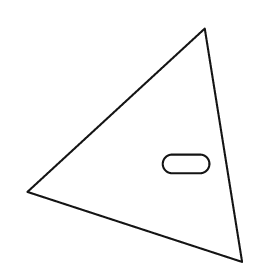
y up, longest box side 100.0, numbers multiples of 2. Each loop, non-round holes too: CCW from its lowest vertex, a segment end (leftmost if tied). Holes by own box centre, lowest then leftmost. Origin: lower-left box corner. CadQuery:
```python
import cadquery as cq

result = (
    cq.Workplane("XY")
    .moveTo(92.0, 0.0)
    .lineTo(76.0, 100.0)
    .lineTo(0.0, 30.0)
    .close()
    .moveTo(62.0, 38.0)
    .lineTo(74.0, 38.0)
    .threePointArc((78.0, 42.0), (74.0, 46.0))
    .lineTo(62.0, 46.0)
    .threePointArc((58.0, 42.0), (62.0, 38.0))
    .close()
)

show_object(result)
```